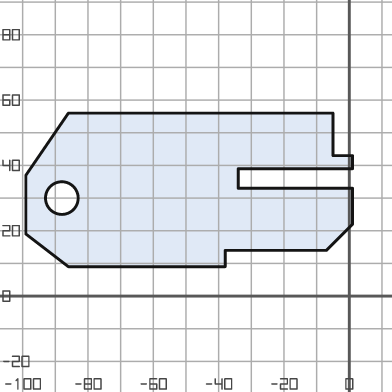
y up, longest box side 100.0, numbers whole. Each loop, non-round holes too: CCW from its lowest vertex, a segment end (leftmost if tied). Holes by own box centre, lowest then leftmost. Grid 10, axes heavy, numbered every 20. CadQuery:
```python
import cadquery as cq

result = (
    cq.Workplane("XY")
    .moveTo(-86.0, 9.0)
    .lineTo(-38.0, 9.0)
    .lineTo(-38.0, 14.0)
    .lineTo(-7.0, 14.0)
    .lineTo(1.0, 22.0)
    .lineTo(1.0, 33.0)
    .lineTo(-34.0, 33.0)
    .lineTo(-34.0, 39.0)
    .lineTo(1.0, 39.0)
    .lineTo(1.0, 43.0)
    .lineTo(-5.0, 43.0)
    .lineTo(-5.0, 56.0)
    .lineTo(-86.0, 56.0)
    .lineTo(-99.0, 37.0)
    .lineTo(-99.0, 19.0)
    .close()
    .moveTo(-88.0, 30.0)
    .circle(5.0)
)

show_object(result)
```